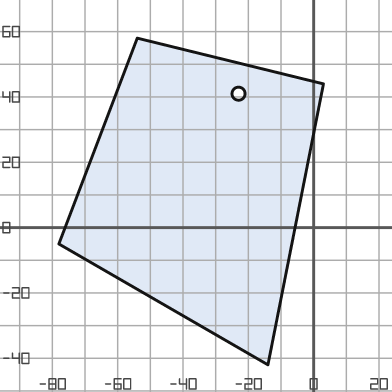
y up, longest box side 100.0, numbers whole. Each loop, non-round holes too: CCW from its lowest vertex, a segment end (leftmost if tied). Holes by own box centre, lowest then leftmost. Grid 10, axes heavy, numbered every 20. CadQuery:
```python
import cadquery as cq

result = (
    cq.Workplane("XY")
    .moveTo(-14.0, -42.0)
    .lineTo(3.0, 44.0)
    .lineTo(-54.0, 58.0)
    .lineTo(-78.0, -5.0)
    .close()
    .moveTo(-23.0, 41.0)
    .circle(2.0)
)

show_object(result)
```